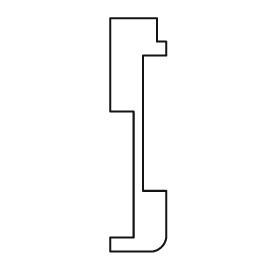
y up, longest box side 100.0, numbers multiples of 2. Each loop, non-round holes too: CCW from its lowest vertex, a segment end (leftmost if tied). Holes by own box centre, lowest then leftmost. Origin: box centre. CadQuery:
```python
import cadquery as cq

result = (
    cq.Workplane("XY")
    .moveTo(-12.0, -50.0)
    .lineTo(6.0, -50.0)
    .threePointArc((10.0, -48.0), (12.0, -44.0))
    .lineTo(12.0, -24.0)
    .lineTo(2.0, -24.0)
    .lineTo(2.0, 34.0)
    .lineTo(12.0, 34.0)
    .lineTo(12.0, 40.0)
    .lineTo(8.0, 40.0)
    .lineTo(8.0, 50.0)
    .lineTo(-12.0, 50.0)
    .lineTo(-12.0, 10.0)
    .lineTo(-2.0, 10.0)
    .lineTo(-2.0, -44.0)
    .lineTo(-12.0, -44.0)
    .close()
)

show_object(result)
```